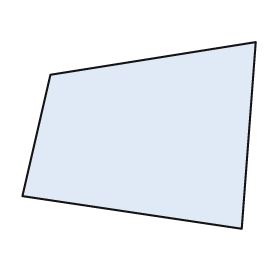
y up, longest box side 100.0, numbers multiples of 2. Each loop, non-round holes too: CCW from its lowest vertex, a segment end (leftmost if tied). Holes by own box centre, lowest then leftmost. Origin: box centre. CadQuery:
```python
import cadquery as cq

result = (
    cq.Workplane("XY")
    .moveTo(44.0, -40.0)
    .lineTo(50.0, 40.0)
    .lineTo(-38.0, 26.0)
    .lineTo(-50.0, -26.0)
    .close()
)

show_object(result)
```